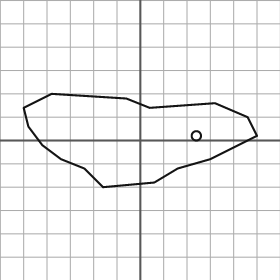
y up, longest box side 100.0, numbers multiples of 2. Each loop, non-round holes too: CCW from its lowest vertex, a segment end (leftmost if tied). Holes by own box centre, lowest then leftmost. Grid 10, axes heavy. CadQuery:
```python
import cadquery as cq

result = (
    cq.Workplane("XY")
    .moveTo(-16.0, -20.0)
    .lineTo(6.0, -18.0)
    .lineTo(16.0, -12.0)
    .lineTo(30.0, -8.0)
    .lineTo(50.0, 2.0)
    .lineTo(46.0, 10.0)
    .lineTo(32.0, 16.0)
    .lineTo(4.0, 14.0)
    .lineTo(-6.0, 18.0)
    .lineTo(-38.0, 20.0)
    .lineTo(-50.0, 14.0)
    .lineTo(-48.0, 6.0)
    .lineTo(-42.0, -2.0)
    .lineTo(-34.0, -8.0)
    .lineTo(-24.0, -12.0)
    .close()
    .moveTo(24.0, 2.0)
    .circle(2.0)
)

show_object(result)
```